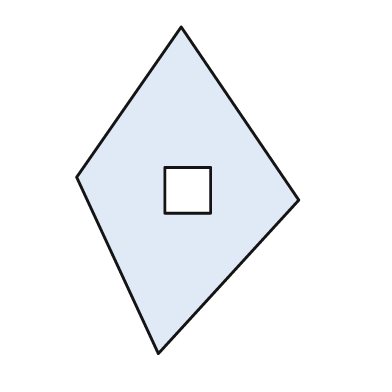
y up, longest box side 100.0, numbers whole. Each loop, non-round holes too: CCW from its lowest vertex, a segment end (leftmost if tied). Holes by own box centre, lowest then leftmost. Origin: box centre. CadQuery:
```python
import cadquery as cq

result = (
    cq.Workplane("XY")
    .moveTo(-9.0, -50.0)
    .lineTo(34.0, -3.0)
    .lineTo(-2.0, 50.0)
    .lineTo(-34.0, 4.0)
    .close()
    .moveTo(-7.0, -7.0)
    .lineTo(7.0, -7.0)
    .lineTo(7.0, 7.0)
    .lineTo(-7.0, 7.0)
    .close()
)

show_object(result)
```